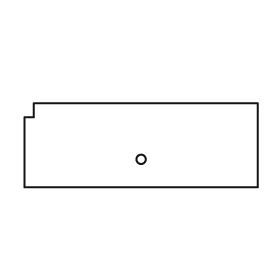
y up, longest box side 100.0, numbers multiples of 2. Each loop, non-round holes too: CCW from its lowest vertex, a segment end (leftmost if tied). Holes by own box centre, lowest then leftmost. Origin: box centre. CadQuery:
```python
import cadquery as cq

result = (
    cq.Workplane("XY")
    .moveTo(-50.0, -18.0)
    .lineTo(50.0, -18.0)
    .lineTo(50.0, 18.0)
    .lineTo(-46.0, 18.0)
    .lineTo(-46.0, 12.0)
    .lineTo(-50.0, 12.0)
    .close()
    .moveTo(0.0, -6.0)
    .circle(2.0)
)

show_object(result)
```